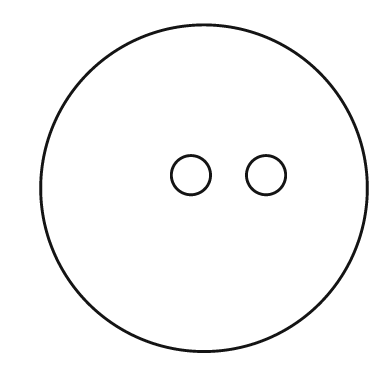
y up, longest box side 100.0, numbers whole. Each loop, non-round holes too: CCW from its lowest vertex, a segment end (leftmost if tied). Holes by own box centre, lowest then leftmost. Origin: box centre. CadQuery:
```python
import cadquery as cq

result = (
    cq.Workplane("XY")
    .moveTo(0.0, 0.0)
    .circle(50.0)
    .moveTo(-4.0, 4.0)
    .circle(6.0)
    .moveTo(19.0, 4.0)
    .circle(6.0)
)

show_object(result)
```